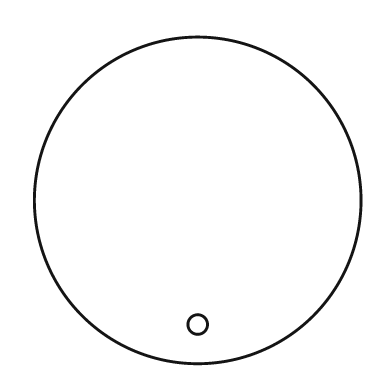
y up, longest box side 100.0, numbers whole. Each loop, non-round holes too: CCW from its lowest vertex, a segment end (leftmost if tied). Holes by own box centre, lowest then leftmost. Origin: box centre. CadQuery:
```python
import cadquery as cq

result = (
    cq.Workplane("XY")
    .moveTo(0.0, 0.0)
    .circle(50.0)
    .moveTo(0.0, -38.0)
    .circle(3.0)
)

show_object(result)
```